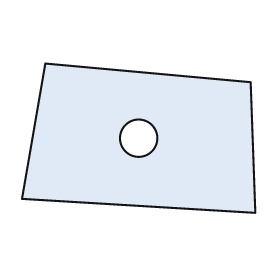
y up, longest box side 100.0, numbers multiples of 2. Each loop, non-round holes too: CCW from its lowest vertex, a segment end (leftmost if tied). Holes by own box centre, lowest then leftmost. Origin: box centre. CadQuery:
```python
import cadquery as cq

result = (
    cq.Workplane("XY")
    .moveTo(50.0, -32.0)
    .lineTo(48.0, 24.0)
    .lineTo(-40.0, 32.0)
    .lineTo(-50.0, -26.0)
    .close()
    .moveTo(0.0, 0.0)
    .circle(8.0)
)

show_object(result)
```